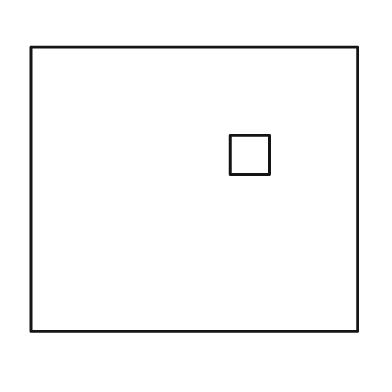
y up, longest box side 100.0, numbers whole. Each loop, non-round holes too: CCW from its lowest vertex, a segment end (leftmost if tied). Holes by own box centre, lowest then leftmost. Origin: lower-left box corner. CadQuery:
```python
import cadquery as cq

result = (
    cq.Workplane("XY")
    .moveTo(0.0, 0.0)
    .lineTo(100.0, 0.0)
    .lineTo(100.0, 87.0)
    .lineTo(0.0, 87.0)
    .close()
    .moveTo(61.0, 48.0)
    .lineTo(73.0, 48.0)
    .lineTo(73.0, 60.0)
    .lineTo(61.0, 60.0)
    .close()
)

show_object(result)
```